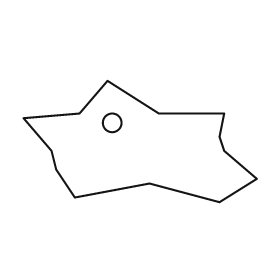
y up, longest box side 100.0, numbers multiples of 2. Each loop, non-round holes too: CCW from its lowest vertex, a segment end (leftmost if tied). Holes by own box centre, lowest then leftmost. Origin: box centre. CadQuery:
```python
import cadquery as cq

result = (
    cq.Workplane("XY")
    .moveTo(34.0, -26.0)
    .lineTo(50.0, -16.0)
    .lineTo(36.0, -4.0)
    .lineTo(34.0, 2.0)
    .lineTo(36.0, 12.0)
    .lineTo(8.0, 12.0)
    .lineTo(-14.0, 26.0)
    .lineTo(-26.0, 12.0)
    .lineTo(-50.0, 10.0)
    .lineTo(-38.0, -4.0)
    .lineTo(-36.0, -12.0)
    .lineTo(-28.0, -24.0)
    .lineTo(4.0, -18.0)
    .close()
    .moveTo(-12.0, 8.0)
    .circle(4.0)
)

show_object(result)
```